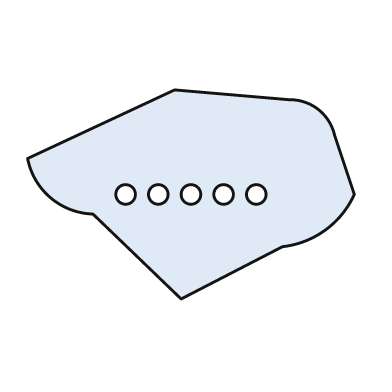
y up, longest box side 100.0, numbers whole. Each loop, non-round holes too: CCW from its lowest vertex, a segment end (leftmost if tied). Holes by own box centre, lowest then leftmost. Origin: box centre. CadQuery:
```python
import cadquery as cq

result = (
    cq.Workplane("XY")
    .moveTo(-3.0, -32.0)
    .lineTo(28.0, -16.0)
    .threePointArc((41.0, -11.0), (50.0, 0.0))
    .lineTo(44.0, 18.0)
    .threePointArc((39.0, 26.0), (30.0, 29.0))
    .lineTo(-5.0, 32.0)
    .lineTo(-50.0, 11.0)
    .threePointArc((-43.0, -1.0), (-30.0, -6.0))
    .close()
    .moveTo(-20.0, 0.0)
    .circle(3.0)
    .moveTo(-10.0, 0.0)
    .circle(3.0)
    .moveTo(0.0, 0.0)
    .circle(3.0)
    .moveTo(10.0, 0.0)
    .circle(3.0)
    .moveTo(20.0, 0.0)
    .circle(3.0)
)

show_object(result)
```